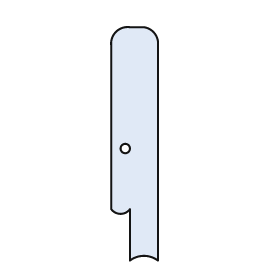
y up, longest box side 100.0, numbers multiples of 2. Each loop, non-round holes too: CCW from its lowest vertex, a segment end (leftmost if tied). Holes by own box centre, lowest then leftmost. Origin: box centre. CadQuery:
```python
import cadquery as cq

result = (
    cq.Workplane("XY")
    .moveTo(-2.0, -50.0)
    .threePointArc((4.0, -48.0), (10.0, -50.0))
    .lineTo(10.0, 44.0)
    .threePointArc((8.0, 48.0), (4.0, 50.0))
    .lineTo(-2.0, 50.0)
    .threePointArc((-8.0, 48.0), (-10.0, 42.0))
    .lineTo(-10.0, -28.0)
    .threePointArc((-6.0, -30.0), (-2.0, -28.0))
    .close()
    .moveTo(-4.0, -2.0)
    .circle(2.0)
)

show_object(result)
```